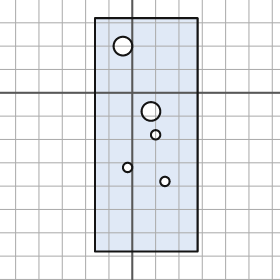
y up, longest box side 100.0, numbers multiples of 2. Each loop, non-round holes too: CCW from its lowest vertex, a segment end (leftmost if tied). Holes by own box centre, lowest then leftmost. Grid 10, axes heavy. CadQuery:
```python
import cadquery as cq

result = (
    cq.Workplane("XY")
    .moveTo(-16.0, -68.0)
    .lineTo(28.0, -68.0)
    .lineTo(28.0, 32.0)
    .lineTo(-16.0, 32.0)
    .close()
    .moveTo(14.0, -38.0)
    .circle(2.0)
    .moveTo(-2.0, -32.0)
    .circle(2.0)
    .moveTo(10.0, -18.0)
    .circle(2.0)
    .moveTo(8.0, -8.0)
    .circle(4.0)
    .moveTo(-4.0, 20.0)
    .circle(4.0)
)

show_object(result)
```